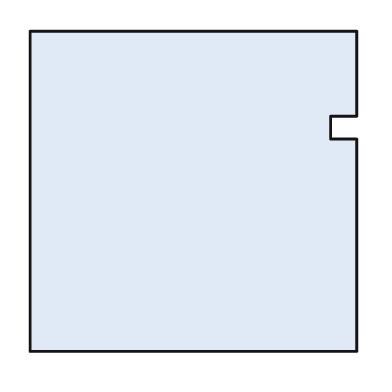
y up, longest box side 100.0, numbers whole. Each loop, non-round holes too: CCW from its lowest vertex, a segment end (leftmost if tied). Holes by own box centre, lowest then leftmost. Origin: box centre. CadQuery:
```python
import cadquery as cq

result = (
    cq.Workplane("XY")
    .moveTo(-50.0, -49.0)
    .lineTo(50.0, -49.0)
    .lineTo(50.0, 16.0)
    .lineTo(42.0, 16.0)
    .lineTo(42.0, 23.0)
    .lineTo(50.0, 23.0)
    .lineTo(50.0, 49.0)
    .lineTo(-50.0, 49.0)
    .close()
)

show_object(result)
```